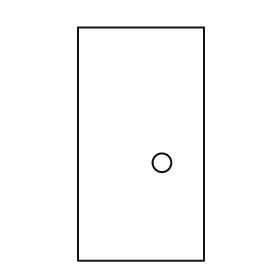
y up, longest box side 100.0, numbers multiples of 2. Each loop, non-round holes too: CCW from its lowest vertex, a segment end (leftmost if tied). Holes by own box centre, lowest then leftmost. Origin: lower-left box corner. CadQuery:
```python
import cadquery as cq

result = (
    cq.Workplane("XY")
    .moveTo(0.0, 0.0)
    .lineTo(54.0, 0.0)
    .lineTo(54.0, 100.0)
    .lineTo(0.0, 100.0)
    .close()
    .moveTo(36.0, 42.0)
    .circle(4.0)
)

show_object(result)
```